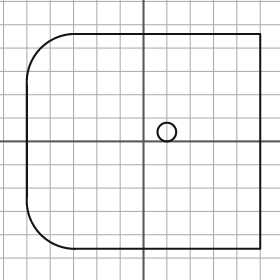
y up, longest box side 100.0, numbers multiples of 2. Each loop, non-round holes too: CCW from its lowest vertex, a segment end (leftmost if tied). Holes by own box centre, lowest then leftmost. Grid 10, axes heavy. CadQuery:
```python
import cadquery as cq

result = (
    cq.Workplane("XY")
    .moveTo(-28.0, -46.0)
    .lineTo(50.0, -46.0)
    .lineTo(50.0, 46.0)
    .lineTo(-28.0, 46.0)
    .threePointArc((-44.0, 40.0), (-50.0, 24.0))
    .lineTo(-50.0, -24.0)
    .threePointArc((-44.0, -40.0), (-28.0, -46.0))
    .close()
    .moveTo(10.0, 4.0)
    .circle(4.0)
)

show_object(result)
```